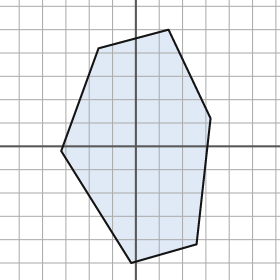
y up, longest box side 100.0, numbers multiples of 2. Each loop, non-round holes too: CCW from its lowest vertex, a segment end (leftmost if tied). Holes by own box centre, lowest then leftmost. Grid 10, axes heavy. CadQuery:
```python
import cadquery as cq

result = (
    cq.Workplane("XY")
    .moveTo(-2.0, -50.0)
    .lineTo(26.0, -42.0)
    .lineTo(32.0, 12.0)
    .lineTo(14.0, 50.0)
    .lineTo(-16.0, 42.0)
    .lineTo(-32.0, -2.0)
    .close()
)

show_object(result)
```